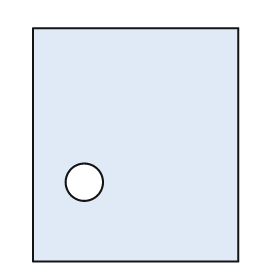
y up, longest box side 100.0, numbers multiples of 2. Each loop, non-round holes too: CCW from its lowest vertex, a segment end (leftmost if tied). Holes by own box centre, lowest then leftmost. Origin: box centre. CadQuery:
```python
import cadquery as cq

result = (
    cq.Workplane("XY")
    .moveTo(-44.0, -50.0)
    .lineTo(44.0, -50.0)
    .lineTo(44.0, 50.0)
    .lineTo(-44.0, 50.0)
    .close()
    .moveTo(-22.0, -16.0)
    .circle(8.0)
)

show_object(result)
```